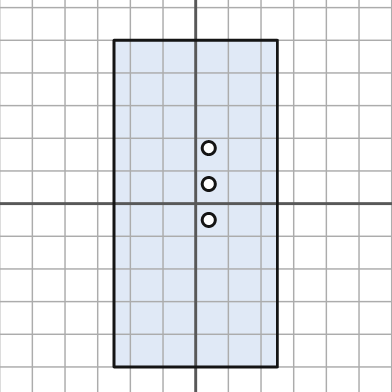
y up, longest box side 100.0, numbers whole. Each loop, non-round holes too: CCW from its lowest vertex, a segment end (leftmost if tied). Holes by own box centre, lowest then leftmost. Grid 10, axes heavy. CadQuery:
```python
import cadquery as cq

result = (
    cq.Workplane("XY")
    .moveTo(-25.0, -50.0)
    .lineTo(25.0, -50.0)
    .lineTo(25.0, 50.0)
    .lineTo(-25.0, 50.0)
    .close()
    .moveTo(4.0, -5.0)
    .circle(2.0)
    .moveTo(4.0, 6.0)
    .circle(2.0)
    .moveTo(4.0, 17.0)
    .circle(2.0)
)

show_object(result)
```